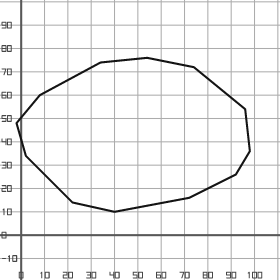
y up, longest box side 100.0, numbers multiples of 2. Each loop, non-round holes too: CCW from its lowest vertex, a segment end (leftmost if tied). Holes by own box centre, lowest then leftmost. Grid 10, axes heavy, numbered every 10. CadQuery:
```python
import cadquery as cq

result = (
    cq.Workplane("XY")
    .moveTo(40.0, 10.0)
    .lineTo(72.0, 16.0)
    .lineTo(92.0, 26.0)
    .lineTo(98.0, 36.0)
    .lineTo(96.0, 54.0)
    .lineTo(74.0, 72.0)
    .lineTo(54.0, 76.0)
    .lineTo(34.0, 74.0)
    .lineTo(8.0, 60.0)
    .lineTo(-2.0, 48.0)
    .lineTo(2.0, 34.0)
    .lineTo(22.0, 14.0)
    .close()
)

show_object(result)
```